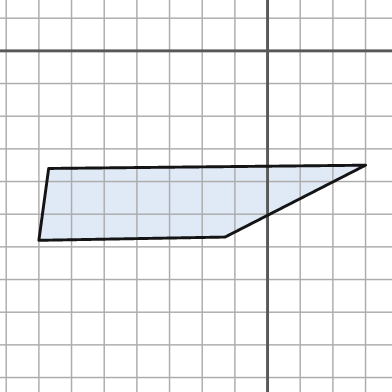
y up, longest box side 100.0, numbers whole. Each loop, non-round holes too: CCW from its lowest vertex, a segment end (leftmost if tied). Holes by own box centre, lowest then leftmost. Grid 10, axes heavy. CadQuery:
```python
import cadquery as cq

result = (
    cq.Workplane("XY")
    .moveTo(-70.0, -58.0)
    .lineTo(-13.0, -57.0)
    .lineTo(30.0, -35.0)
    .lineTo(-67.0, -36.0)
    .close()
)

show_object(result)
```